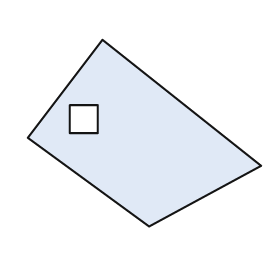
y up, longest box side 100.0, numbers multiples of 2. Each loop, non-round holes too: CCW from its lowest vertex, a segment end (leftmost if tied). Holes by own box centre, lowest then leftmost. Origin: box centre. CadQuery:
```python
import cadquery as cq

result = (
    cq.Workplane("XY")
    .moveTo(2.0, -40.0)
    .lineTo(50.0, -14.0)
    .lineTo(-18.0, 40.0)
    .lineTo(-50.0, -2.0)
    .close()
    .moveTo(-32.0, 0.0)
    .lineTo(-20.0, 0.0)
    .lineTo(-20.0, 12.0)
    .lineTo(-32.0, 12.0)
    .close()
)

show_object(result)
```